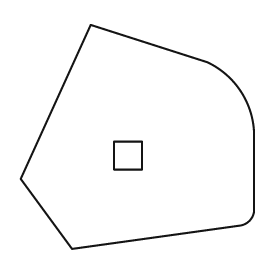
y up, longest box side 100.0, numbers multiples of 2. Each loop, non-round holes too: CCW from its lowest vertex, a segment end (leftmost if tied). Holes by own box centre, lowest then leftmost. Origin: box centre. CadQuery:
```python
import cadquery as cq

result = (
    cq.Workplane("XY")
    .moveTo(-28.0, -48.0)
    .lineTo(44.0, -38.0)
    .threePointArc((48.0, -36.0), (50.0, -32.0))
    .lineTo(50.0, 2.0)
    .threePointArc((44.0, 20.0), (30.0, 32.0))
    .lineTo(-20.0, 48.0)
    .lineTo(-50.0, -18.0)
    .close()
    .moveTo(-10.0, -14.0)
    .lineTo(2.0, -14.0)
    .lineTo(2.0, -2.0)
    .lineTo(-10.0, -2.0)
    .close()
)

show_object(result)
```